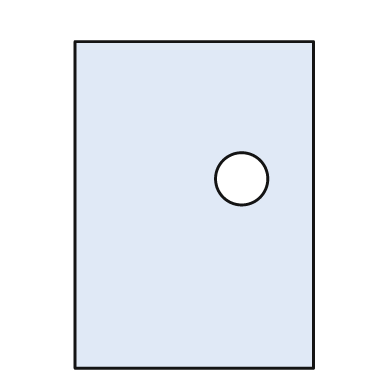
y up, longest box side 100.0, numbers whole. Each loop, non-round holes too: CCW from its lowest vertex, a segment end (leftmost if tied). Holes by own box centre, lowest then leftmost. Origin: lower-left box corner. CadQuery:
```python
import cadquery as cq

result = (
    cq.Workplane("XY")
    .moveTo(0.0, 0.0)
    .lineTo(73.0, 0.0)
    .lineTo(73.0, 100.0)
    .lineTo(0.0, 100.0)
    .close()
    .moveTo(51.0, 58.0)
    .circle(8.0)
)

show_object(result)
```